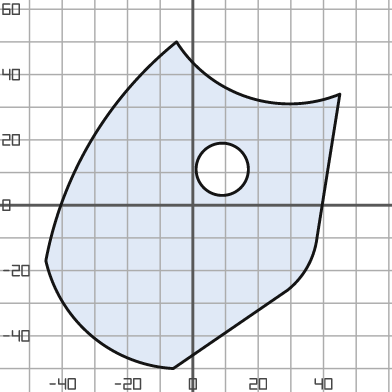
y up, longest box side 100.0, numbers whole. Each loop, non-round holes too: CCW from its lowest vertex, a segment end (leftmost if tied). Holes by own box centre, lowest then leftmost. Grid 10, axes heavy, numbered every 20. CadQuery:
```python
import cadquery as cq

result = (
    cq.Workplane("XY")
    .moveTo(-6.0, -50.0)
    .lineTo(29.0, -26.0)
    .threePointArc((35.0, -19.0), (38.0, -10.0))
    .lineTo(45.0, 34.0)
    .threePointArc((17.0, 33.0), (-5.0, 50.0))
    .threePointArc((-31.0, 20.0), (-45.0, -17.0))
    .threePointArc((-31.0, -40.0), (-6.0, -50.0))
    .close()
    .moveTo(9.0, 11.0)
    .circle(8.0)
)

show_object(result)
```